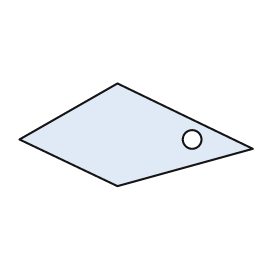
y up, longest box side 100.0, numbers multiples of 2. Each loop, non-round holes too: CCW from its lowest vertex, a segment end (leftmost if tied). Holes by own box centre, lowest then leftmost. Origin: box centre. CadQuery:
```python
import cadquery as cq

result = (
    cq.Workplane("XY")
    .moveTo(-8.0, -22.0)
    .lineTo(50.0, -6.0)
    .lineTo(-8.0, 22.0)
    .lineTo(-50.0, -2.0)
    .close()
    .moveTo(24.0, -2.0)
    .circle(4.0)
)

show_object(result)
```